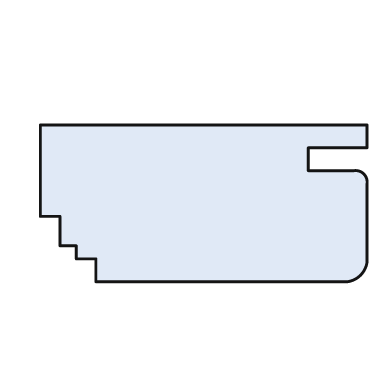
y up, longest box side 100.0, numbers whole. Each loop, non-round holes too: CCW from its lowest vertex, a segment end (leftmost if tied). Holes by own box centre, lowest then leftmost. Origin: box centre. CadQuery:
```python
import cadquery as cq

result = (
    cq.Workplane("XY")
    .moveTo(-33.0, -24.0)
    .lineTo(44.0, -24.0)
    .threePointArc((48.0, -22.0), (50.0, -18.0))
    .lineTo(50.0, 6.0)
    .threePointArc((49.0, 9.0), (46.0, 10.0))
    .lineTo(32.0, 10.0)
    .lineTo(32.0, 17.0)
    .lineTo(50.0, 17.0)
    .lineTo(50.0, 24.0)
    .lineTo(-50.0, 24.0)
    .lineTo(-50.0, -4.0)
    .lineTo(-44.0, -4.0)
    .lineTo(-44.0, -13.0)
    .lineTo(-39.0, -13.0)
    .lineTo(-39.0, -17.0)
    .lineTo(-33.0, -17.0)
    .close()
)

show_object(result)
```